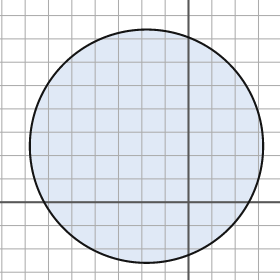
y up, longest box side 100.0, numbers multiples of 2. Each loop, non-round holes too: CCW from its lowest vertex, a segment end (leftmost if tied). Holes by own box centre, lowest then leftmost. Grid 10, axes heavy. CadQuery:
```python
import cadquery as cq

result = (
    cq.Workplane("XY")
    .moveTo(-18.0, 24.0)
    .circle(50.0)
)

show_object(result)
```